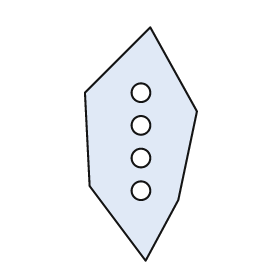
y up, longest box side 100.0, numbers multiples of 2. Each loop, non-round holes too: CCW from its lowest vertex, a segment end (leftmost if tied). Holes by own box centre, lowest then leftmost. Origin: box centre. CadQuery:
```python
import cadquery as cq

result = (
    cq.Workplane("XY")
    .moveTo(2.0, -50.0)
    .lineTo(16.0, -24.0)
    .lineTo(24.0, 14.0)
    .lineTo(4.0, 50.0)
    .lineTo(-24.0, 22.0)
    .lineTo(-22.0, -18.0)
    .close()
    .moveTo(0.0, -20.0)
    .circle(4.0)
    .moveTo(0.0, -6.0)
    .circle(4.0)
    .moveTo(0.0, 8.0)
    .circle(4.0)
    .moveTo(0.0, 22.0)
    .circle(4.0)
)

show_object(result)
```